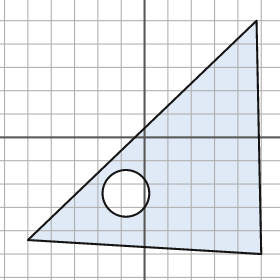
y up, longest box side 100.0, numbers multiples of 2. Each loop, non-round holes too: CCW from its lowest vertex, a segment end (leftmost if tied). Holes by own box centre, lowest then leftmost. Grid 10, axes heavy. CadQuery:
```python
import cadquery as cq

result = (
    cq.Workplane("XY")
    .moveTo(50.0, -50.0)
    .lineTo(48.0, 50.0)
    .lineTo(-50.0, -44.0)
    .close()
    .moveTo(-8.0, -24.0)
    .circle(10.0)
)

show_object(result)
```